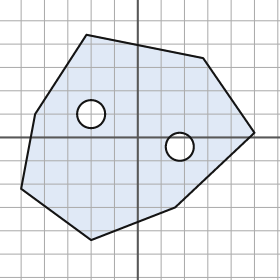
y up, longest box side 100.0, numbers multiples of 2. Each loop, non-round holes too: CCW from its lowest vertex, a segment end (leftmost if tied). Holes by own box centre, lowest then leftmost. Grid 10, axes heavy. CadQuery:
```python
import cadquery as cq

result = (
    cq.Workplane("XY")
    .moveTo(-20.0, -44.0)
    .lineTo(16.0, -30.0)
    .lineTo(50.0, 2.0)
    .lineTo(28.0, 34.0)
    .lineTo(-22.0, 44.0)
    .lineTo(-44.0, 10.0)
    .lineTo(-50.0, -22.0)
    .close()
    .moveTo(18.0, -4.0)
    .circle(6.0)
    .moveTo(-20.0, 10.0)
    .circle(6.0)
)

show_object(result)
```